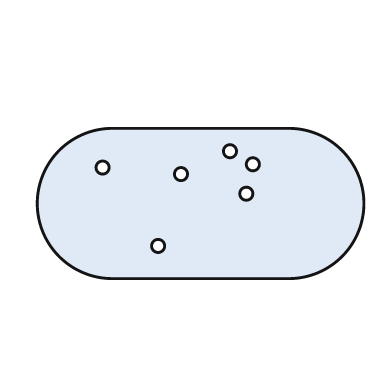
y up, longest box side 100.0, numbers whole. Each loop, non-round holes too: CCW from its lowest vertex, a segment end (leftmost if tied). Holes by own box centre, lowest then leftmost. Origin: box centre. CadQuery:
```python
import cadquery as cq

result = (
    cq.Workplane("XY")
    .moveTo(-27.0, -23.0)
    .lineTo(27.0, -23.0)
    .threePointArc((50.0, 0.0), (27.0, 23.0))
    .lineTo(-27.0, 23.0)
    .threePointArc((-50.0, 0.0), (-27.0, -23.0))
    .close()
    .moveTo(-13.0, -13.0)
    .circle(2.0)
    .moveTo(14.0, 3.0)
    .circle(2.0)
    .moveTo(-6.0, 9.0)
    .circle(2.0)
    .moveTo(-30.0, 11.0)
    .circle(2.0)
    .moveTo(16.0, 12.0)
    .circle(2.0)
    .moveTo(9.0, 16.0)
    .circle(2.0)
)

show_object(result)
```